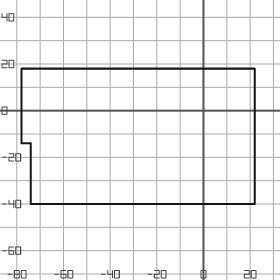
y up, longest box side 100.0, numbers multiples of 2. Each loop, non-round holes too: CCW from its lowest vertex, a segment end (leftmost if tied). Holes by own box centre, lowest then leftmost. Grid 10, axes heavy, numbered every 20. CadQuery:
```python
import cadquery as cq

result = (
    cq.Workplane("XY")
    .moveTo(-74.0, -40.0)
    .lineTo(22.0, -40.0)
    .lineTo(22.0, 18.0)
    .lineTo(-78.0, 18.0)
    .lineTo(-78.0, -14.0)
    .lineTo(-74.0, -14.0)
    .close()
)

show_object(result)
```